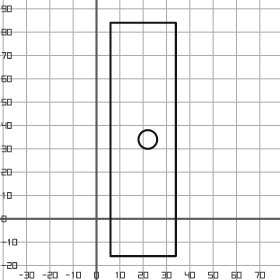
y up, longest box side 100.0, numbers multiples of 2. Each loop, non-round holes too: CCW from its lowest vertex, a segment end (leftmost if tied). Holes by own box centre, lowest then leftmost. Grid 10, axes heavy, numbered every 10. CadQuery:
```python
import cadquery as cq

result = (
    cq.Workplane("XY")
    .moveTo(6.0, -16.0)
    .lineTo(34.0, -16.0)
    .lineTo(34.0, 84.0)
    .lineTo(6.0, 84.0)
    .close()
    .moveTo(22.0, 34.0)
    .circle(4.0)
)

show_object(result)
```